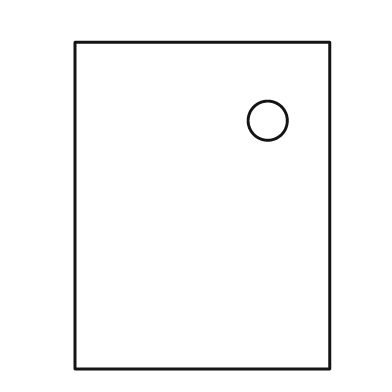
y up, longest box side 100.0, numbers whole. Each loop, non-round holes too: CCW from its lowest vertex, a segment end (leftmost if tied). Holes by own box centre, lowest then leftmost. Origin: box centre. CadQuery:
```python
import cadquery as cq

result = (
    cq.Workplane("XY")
    .moveTo(-39.0, -50.0)
    .lineTo(39.0, -50.0)
    .lineTo(39.0, 50.0)
    .lineTo(-39.0, 50.0)
    .close()
    .moveTo(20.0, 26.0)
    .circle(6.0)
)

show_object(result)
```